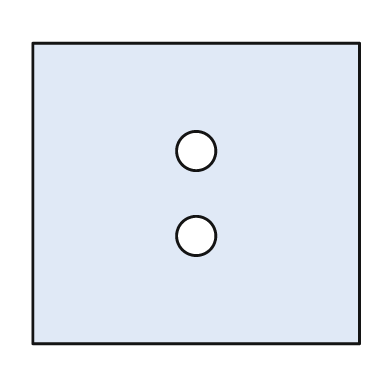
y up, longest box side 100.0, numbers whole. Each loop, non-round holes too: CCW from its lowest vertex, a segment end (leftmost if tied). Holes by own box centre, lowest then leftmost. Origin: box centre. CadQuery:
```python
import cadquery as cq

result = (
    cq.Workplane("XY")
    .moveTo(-50.0, -46.0)
    .lineTo(50.0, -46.0)
    .lineTo(50.0, 46.0)
    .lineTo(-50.0, 46.0)
    .close()
    .moveTo(0.0, -13.0)
    .circle(6.0)
    .moveTo(0.0, 13.0)
    .circle(6.0)
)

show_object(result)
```